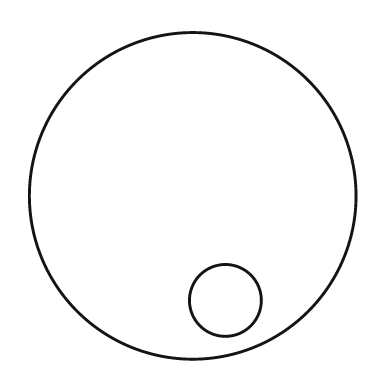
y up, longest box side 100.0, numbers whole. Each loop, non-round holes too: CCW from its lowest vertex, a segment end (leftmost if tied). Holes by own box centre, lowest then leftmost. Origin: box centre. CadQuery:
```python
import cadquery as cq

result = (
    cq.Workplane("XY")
    .moveTo(0.0, 0.0)
    .circle(50.0)
    .moveTo(10.0, -32.0)
    .circle(11.0)
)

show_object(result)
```